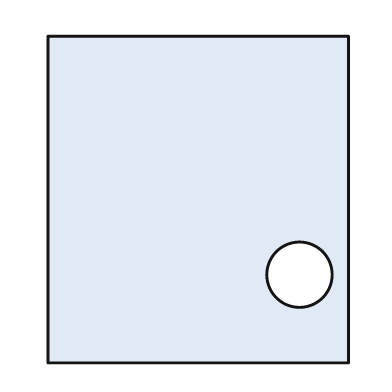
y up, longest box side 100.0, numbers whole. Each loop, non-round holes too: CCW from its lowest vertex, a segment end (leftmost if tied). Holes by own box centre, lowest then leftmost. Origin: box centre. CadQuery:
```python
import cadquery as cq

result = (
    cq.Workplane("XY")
    .moveTo(-46.0, -50.0)
    .lineTo(46.0, -50.0)
    .lineTo(46.0, 50.0)
    .lineTo(-46.0, 50.0)
    .close()
    .moveTo(31.0, -23.0)
    .circle(10.0)
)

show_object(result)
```